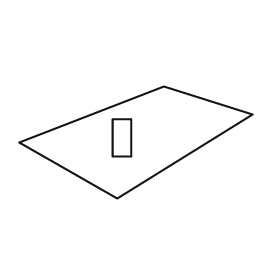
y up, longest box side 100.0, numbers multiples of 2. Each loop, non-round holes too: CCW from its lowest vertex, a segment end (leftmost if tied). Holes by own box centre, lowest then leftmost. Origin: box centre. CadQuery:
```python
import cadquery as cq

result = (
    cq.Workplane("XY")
    .moveTo(-8.0, -24.0)
    .lineTo(50.0, 12.0)
    .lineTo(12.0, 24.0)
    .lineTo(-50.0, 0.0)
    .close()
    .moveTo(-10.0, -6.0)
    .lineTo(-2.0, -6.0)
    .lineTo(-2.0, 10.0)
    .lineTo(-10.0, 10.0)
    .close()
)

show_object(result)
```